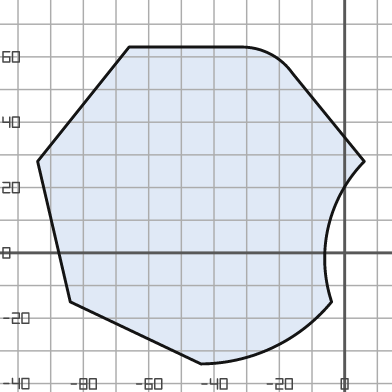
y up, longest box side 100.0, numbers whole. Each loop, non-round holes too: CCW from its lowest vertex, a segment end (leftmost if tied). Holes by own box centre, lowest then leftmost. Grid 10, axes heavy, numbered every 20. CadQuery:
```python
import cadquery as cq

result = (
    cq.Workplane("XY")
    .moveTo(-44.0, -34.0)
    .threePointArc((-22.0, -29.0), (-4.0, -15.0))
    .threePointArc((-5.0, 8.0), (6.0, 28.0))
    .lineTo(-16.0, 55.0)
    .threePointArc((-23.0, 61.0), (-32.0, 63.0))
    .lineTo(-66.0, 63.0)
    .lineTo(-94.0, 28.0)
    .lineTo(-84.0, -15.0)
    .close()
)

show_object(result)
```